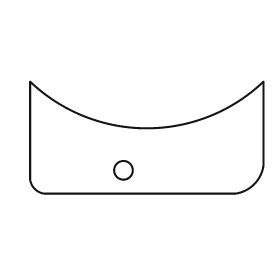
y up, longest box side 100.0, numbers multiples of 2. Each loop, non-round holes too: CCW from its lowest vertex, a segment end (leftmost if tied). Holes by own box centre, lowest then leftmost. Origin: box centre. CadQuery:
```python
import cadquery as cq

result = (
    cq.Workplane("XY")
    .moveTo(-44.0, -24.0)
    .lineTo(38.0, -24.0)
    .threePointArc((46.0, -20.0), (50.0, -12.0))
    .lineTo(50.0, 24.0)
    .threePointArc((0.0, 4.0), (-50.0, 24.0))
    .lineTo(-50.0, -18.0)
    .threePointArc((-48.0, -22.0), (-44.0, -24.0))
    .close()
    .moveTo(-10.0, -14.0)
    .circle(4.0)
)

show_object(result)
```